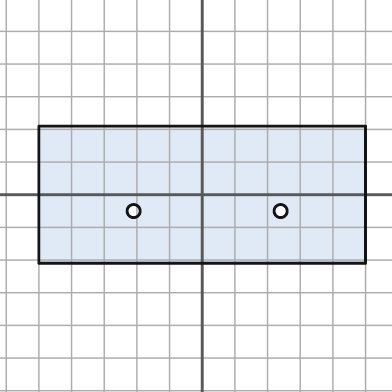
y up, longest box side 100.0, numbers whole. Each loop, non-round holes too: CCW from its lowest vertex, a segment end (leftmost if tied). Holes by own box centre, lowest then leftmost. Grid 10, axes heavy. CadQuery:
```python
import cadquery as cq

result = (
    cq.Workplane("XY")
    .moveTo(-50.0, -21.0)
    .lineTo(50.0, -21.0)
    .lineTo(50.0, 21.0)
    .lineTo(-50.0, 21.0)
    .close()
    .moveTo(-21.0, -5.0)
    .circle(2.0)
    .moveTo(24.0, -5.0)
    .circle(2.0)
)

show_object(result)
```